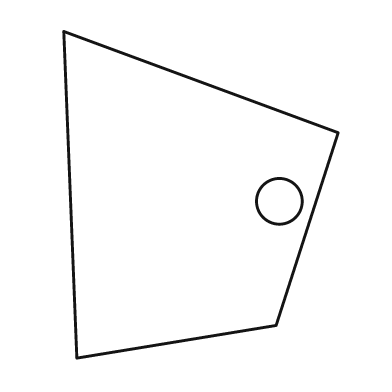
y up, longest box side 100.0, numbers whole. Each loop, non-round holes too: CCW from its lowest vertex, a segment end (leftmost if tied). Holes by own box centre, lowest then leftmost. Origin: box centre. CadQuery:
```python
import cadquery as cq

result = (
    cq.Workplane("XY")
    .moveTo(-38.0, -50.0)
    .lineTo(23.0, -40.0)
    .lineTo(42.0, 19.0)
    .lineTo(-42.0, 50.0)
    .close()
    .moveTo(24.0, -2.0)
    .circle(7.0)
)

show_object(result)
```